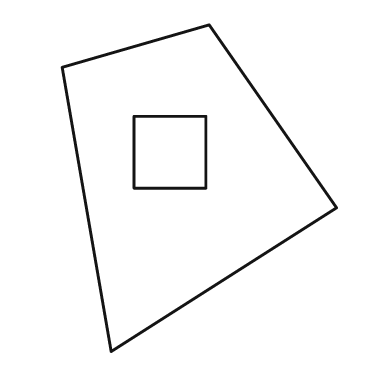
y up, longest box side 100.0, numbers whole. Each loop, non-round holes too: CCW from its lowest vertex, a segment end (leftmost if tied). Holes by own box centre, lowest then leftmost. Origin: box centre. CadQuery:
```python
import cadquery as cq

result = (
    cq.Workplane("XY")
    .moveTo(-27.0, -50.0)
    .lineTo(42.0, -6.0)
    .lineTo(3.0, 50.0)
    .lineTo(-42.0, 37.0)
    .close()
    .moveTo(-20.0, 0.0)
    .lineTo(2.0, 0.0)
    .lineTo(2.0, 22.0)
    .lineTo(-20.0, 22.0)
    .close()
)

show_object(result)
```